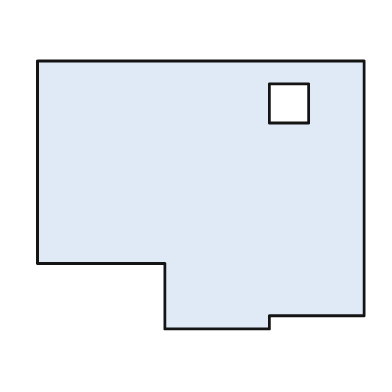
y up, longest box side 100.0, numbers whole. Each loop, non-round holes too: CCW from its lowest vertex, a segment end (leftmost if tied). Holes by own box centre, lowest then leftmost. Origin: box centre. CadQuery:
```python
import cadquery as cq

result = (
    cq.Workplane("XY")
    .moveTo(-11.0, -41.0)
    .lineTo(21.0, -41.0)
    .lineTo(21.0, -37.0)
    .lineTo(50.0, -37.0)
    .lineTo(50.0, 41.0)
    .lineTo(-50.0, 41.0)
    .lineTo(-50.0, -21.0)
    .lineTo(-11.0, -21.0)
    .close()
    .moveTo(21.0, 22.0)
    .lineTo(33.0, 22.0)
    .lineTo(33.0, 34.0)
    .lineTo(21.0, 34.0)
    .close()
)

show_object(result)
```